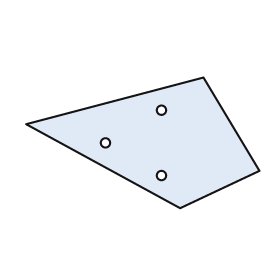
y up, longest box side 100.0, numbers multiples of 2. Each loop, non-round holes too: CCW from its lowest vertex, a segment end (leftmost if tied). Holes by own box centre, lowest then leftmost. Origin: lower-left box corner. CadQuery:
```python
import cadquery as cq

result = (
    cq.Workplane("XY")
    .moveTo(66.0, 0.0)
    .lineTo(100.0, 16.0)
    .lineTo(76.0, 56.0)
    .lineTo(0.0, 36.0)
    .close()
    .moveTo(58.0, 14.0)
    .circle(2.0)
    .moveTo(34.0, 28.0)
    .circle(2.0)
    .moveTo(58.0, 42.0)
    .circle(2.0)
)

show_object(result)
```